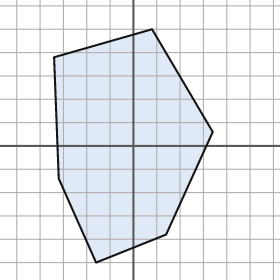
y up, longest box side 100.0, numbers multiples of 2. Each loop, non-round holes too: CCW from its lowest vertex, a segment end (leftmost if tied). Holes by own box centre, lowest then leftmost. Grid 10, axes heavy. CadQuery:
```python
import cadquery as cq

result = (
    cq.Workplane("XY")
    .moveTo(-16.0, -50.0)
    .lineTo(14.0, -38.0)
    .lineTo(34.0, 6.0)
    .lineTo(8.0, 50.0)
    .lineTo(-34.0, 38.0)
    .lineTo(-32.0, -14.0)
    .close()
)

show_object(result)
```